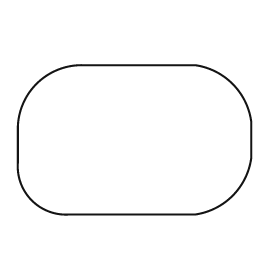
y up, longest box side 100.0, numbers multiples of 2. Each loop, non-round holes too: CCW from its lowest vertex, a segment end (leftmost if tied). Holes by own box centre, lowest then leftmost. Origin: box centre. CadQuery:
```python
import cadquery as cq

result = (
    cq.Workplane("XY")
    .moveTo(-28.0, -32.0)
    .lineTo(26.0, -32.0)
    .threePointArc((42.0, -24.0), (50.0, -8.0))
    .lineTo(50.0, 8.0)
    .threePointArc((42.0, 24.0), (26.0, 32.0))
    .lineTo(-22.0, 32.0)
    .threePointArc((-42.0, 24.0), (-50.0, 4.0))
    .lineTo(-50.0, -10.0)
    .threePointArc((-44.0, -26.0), (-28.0, -32.0))
    .close()
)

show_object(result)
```